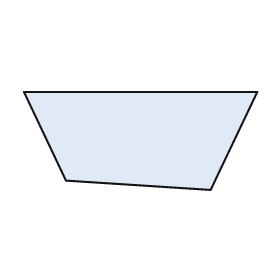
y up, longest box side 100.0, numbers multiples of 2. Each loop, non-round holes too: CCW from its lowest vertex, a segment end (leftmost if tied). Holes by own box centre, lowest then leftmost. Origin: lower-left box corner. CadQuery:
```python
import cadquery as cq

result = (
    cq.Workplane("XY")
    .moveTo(80.0, 0.0)
    .lineTo(100.0, 42.0)
    .lineTo(0.0, 42.0)
    .lineTo(18.0, 4.0)
    .close()
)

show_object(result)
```